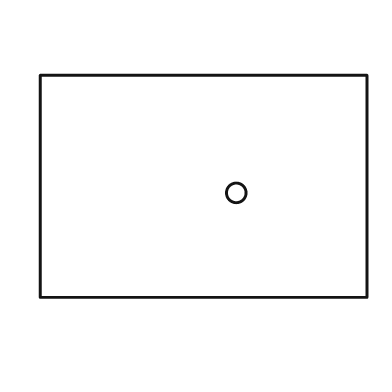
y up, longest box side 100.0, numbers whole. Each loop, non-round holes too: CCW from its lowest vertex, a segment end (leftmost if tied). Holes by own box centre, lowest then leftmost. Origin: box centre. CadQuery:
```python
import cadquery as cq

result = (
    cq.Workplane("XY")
    .moveTo(-50.0, -34.0)
    .lineTo(50.0, -34.0)
    .lineTo(50.0, 34.0)
    .lineTo(-50.0, 34.0)
    .close()
    .moveTo(10.0, -2.0)
    .circle(3.0)
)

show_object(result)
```